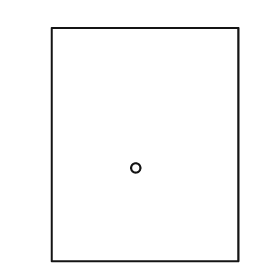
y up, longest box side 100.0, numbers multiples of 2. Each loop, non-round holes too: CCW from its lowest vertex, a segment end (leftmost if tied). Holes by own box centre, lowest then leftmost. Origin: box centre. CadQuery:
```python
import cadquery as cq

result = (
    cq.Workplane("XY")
    .moveTo(-40.0, -50.0)
    .lineTo(40.0, -50.0)
    .lineTo(40.0, 50.0)
    .lineTo(-40.0, 50.0)
    .close()
    .moveTo(-4.0, -10.0)
    .circle(2.0)
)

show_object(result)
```